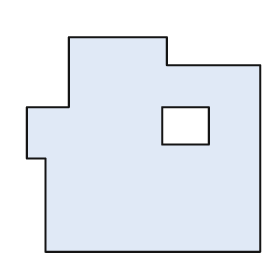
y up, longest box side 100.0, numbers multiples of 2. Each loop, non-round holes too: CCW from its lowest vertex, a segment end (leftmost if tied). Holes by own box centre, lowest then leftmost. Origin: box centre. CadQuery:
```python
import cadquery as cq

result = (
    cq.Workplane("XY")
    .moveTo(-42.0, -46.0)
    .lineTo(50.0, -46.0)
    .lineTo(50.0, 34.0)
    .lineTo(10.0, 34.0)
    .lineTo(10.0, 46.0)
    .lineTo(-32.0, 46.0)
    .lineTo(-32.0, 16.0)
    .lineTo(-50.0, 16.0)
    .lineTo(-50.0, -6.0)
    .lineTo(-42.0, -6.0)
    .close()
    .moveTo(8.0, 0.0)
    .lineTo(28.0, 0.0)
    .lineTo(28.0, 16.0)
    .lineTo(8.0, 16.0)
    .close()
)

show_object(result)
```